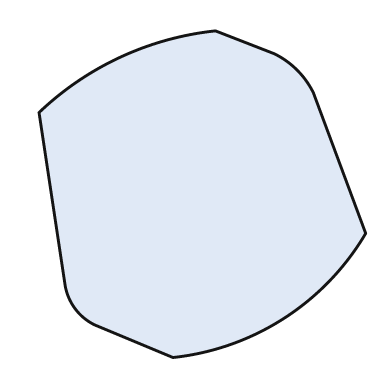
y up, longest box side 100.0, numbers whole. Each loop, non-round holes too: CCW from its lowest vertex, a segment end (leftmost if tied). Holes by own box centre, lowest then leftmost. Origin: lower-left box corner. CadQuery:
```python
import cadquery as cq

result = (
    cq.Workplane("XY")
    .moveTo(41.0, 0.0)
    .threePointArc((75.0, 12.0), (100.0, 38.0))
    .lineTo(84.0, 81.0)
    .threePointArc((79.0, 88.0), (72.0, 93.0))
    .lineTo(54.0, 100.0)
    .threePointArc((25.0, 92.0), (0.0, 75.0))
    .lineTo(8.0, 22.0)
    .threePointArc((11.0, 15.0), (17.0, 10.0))
    .close()
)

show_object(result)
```